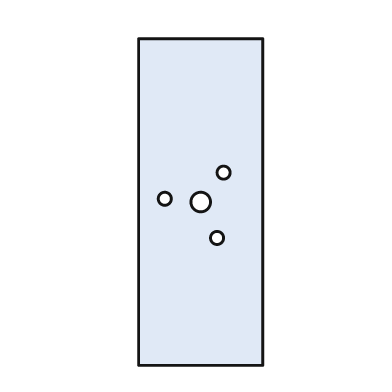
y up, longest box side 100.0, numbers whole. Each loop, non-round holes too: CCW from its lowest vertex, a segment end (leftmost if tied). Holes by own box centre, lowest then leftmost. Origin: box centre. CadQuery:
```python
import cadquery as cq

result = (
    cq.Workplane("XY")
    .moveTo(-19.0, -50.0)
    .lineTo(19.0, -50.0)
    .lineTo(19.0, 50.0)
    .lineTo(-19.0, 50.0)
    .close()
    .moveTo(5.0, -11.0)
    .circle(2.0)
    .moveTo(0.0, 0.0)
    .circle(3.0)
    .moveTo(-11.0, 1.0)
    .circle(2.0)
    .moveTo(7.0, 9.0)
    .circle(2.0)
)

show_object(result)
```